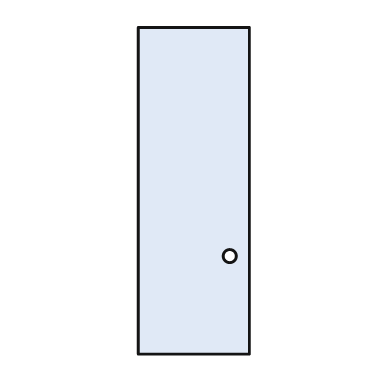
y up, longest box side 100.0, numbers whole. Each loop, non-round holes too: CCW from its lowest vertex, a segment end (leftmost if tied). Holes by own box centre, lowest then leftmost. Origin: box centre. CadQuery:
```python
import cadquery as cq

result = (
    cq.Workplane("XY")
    .moveTo(-17.0, -50.0)
    .lineTo(17.0, -50.0)
    .lineTo(17.0, 50.0)
    .lineTo(-17.0, 50.0)
    .close()
    .moveTo(11.0, -20.0)
    .circle(2.0)
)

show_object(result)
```